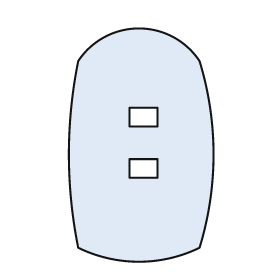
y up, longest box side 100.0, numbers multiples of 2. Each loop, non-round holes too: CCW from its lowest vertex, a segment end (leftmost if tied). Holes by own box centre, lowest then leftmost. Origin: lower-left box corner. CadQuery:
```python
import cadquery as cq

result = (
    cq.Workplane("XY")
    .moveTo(4.0, 6.0)
    .threePointArc((30.0, 0.0), (56.0, 6.0))
    .threePointArc((62.0, 46.0), (56.0, 86.0))
    .threePointArc((30.0, 100.0), (4.0, 86.0))
    .threePointArc((0.0, 46.0), (4.0, 6.0))
    .close()
    .moveTo(26.0, 36.0)
    .lineTo(38.0, 36.0)
    .lineTo(38.0, 44.0)
    .lineTo(26.0, 44.0)
    .close()
    .moveTo(26.0, 58.0)
    .lineTo(38.0, 58.0)
    .lineTo(38.0, 66.0)
    .lineTo(26.0, 66.0)
    .close()
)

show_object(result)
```